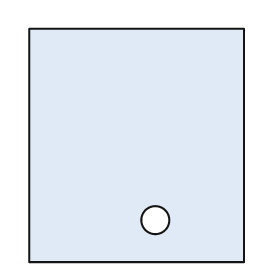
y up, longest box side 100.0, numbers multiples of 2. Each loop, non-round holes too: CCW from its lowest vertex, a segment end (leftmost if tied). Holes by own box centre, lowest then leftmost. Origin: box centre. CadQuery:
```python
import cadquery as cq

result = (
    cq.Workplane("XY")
    .moveTo(-46.0, -50.0)
    .lineTo(46.0, -50.0)
    .lineTo(46.0, 50.0)
    .lineTo(-46.0, 50.0)
    .close()
    .moveTo(8.0, -32.0)
    .circle(6.0)
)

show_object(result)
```